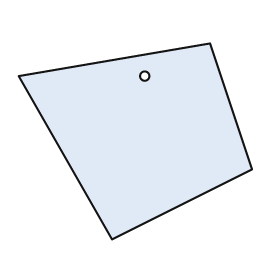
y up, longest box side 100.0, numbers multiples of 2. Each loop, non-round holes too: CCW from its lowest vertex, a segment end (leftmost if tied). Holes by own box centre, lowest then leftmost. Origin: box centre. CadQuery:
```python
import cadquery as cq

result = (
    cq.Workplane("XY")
    .moveTo(-10.0, -42.0)
    .lineTo(50.0, -12.0)
    .lineTo(32.0, 42.0)
    .lineTo(-50.0, 28.0)
    .close()
    .moveTo(4.0, 28.0)
    .circle(2.0)
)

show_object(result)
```